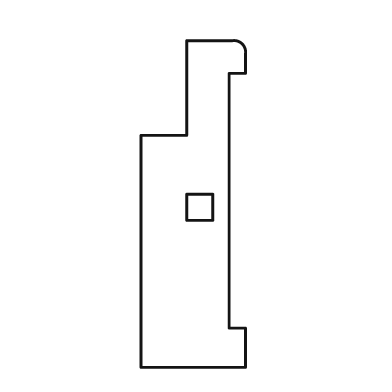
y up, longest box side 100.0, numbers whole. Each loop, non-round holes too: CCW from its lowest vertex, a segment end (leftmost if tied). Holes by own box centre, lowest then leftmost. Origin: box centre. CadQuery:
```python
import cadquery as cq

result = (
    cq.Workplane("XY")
    .moveTo(-16.0, -50.0)
    .lineTo(16.0, -50.0)
    .lineTo(16.0, -38.0)
    .lineTo(11.0, -38.0)
    .lineTo(11.0, 40.0)
    .lineTo(16.0, 40.0)
    .lineTo(16.0, 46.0)
    .threePointArc((15.0, 49.0), (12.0, 50.0))
    .lineTo(-2.0, 50.0)
    .lineTo(-2.0, 21.0)
    .lineTo(-16.0, 21.0)
    .close()
    .moveTo(-2.0, -5.0)
    .lineTo(6.0, -5.0)
    .lineTo(6.0, 3.0)
    .lineTo(-2.0, 3.0)
    .close()
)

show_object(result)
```